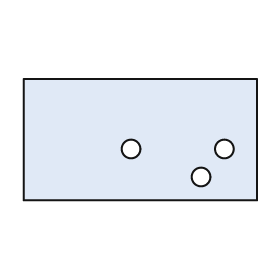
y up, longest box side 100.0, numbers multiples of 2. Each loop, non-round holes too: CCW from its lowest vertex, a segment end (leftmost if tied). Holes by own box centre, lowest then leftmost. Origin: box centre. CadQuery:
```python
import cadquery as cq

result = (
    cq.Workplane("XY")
    .moveTo(-50.0, -26.0)
    .lineTo(50.0, -26.0)
    .lineTo(50.0, 26.0)
    .lineTo(-50.0, 26.0)
    .close()
    .moveTo(26.0, -16.0)
    .circle(4.0)
    .moveTo(-4.0, -4.0)
    .circle(4.0)
    .moveTo(36.0, -4.0)
    .circle(4.0)
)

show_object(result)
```